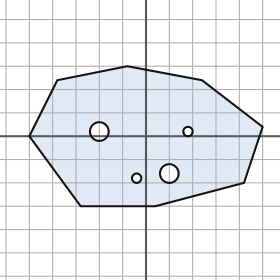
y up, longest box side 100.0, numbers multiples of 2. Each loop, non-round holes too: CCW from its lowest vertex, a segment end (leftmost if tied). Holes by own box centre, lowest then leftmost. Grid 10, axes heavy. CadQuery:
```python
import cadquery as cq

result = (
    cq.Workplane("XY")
    .moveTo(-28.0, -30.0)
    .lineTo(4.0, -30.0)
    .lineTo(42.0, -20.0)
    .lineTo(50.0, 4.0)
    .lineTo(24.0, 24.0)
    .lineTo(-8.0, 30.0)
    .lineTo(-38.0, 24.0)
    .lineTo(-50.0, 0.0)
    .close()
    .moveTo(-4.0, -18.0)
    .circle(2.0)
    .moveTo(10.0, -16.0)
    .circle(4.0)
    .moveTo(-20.0, 2.0)
    .circle(4.0)
    .moveTo(18.0, 2.0)
    .circle(2.0)
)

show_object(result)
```